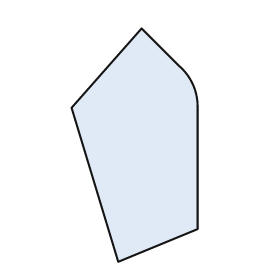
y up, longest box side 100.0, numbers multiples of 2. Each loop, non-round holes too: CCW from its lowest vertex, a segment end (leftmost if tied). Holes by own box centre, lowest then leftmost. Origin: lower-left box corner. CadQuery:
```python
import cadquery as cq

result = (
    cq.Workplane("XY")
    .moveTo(20.0, 0.0)
    .lineTo(54.0, 14.0)
    .lineTo(54.0, 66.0)
    .threePointArc((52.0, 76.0), (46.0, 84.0))
    .lineTo(30.0, 100.0)
    .lineTo(0.0, 66.0)
    .close()
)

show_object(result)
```